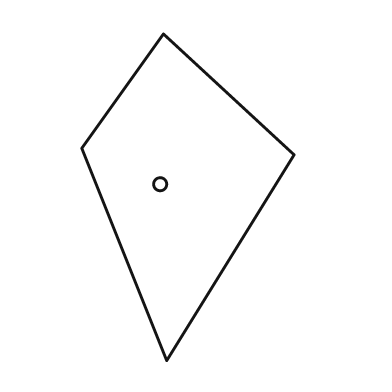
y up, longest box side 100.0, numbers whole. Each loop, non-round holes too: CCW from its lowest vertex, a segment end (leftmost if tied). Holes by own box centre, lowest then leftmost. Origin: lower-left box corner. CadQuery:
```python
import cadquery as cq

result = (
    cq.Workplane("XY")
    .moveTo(26.0, 0.0)
    .lineTo(65.0, 63.0)
    .lineTo(25.0, 100.0)
    .lineTo(0.0, 65.0)
    .close()
    .moveTo(24.0, 54.0)
    .circle(2.0)
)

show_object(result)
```